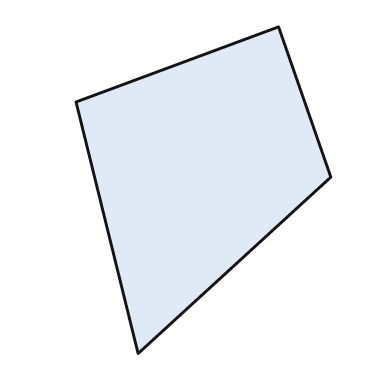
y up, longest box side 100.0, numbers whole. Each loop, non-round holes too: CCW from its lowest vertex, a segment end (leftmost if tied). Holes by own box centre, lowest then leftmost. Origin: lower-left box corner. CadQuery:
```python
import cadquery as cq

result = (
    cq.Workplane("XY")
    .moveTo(19.0, 0.0)
    .lineTo(78.0, 54.0)
    .lineTo(62.0, 100.0)
    .lineTo(0.0, 77.0)
    .close()
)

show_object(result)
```